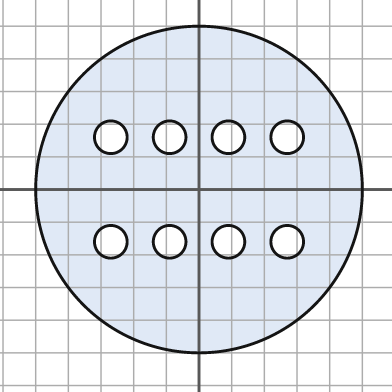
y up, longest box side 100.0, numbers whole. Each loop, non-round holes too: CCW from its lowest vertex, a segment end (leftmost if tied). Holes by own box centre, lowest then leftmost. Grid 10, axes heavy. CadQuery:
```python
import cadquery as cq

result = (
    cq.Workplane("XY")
    .moveTo(0.0, 0.0)
    .circle(50.0)
    .moveTo(-27.0, -16.0)
    .circle(5.0)
    .moveTo(-9.0, -16.0)
    .circle(5.0)
    .moveTo(9.0, -16.0)
    .circle(5.0)
    .moveTo(27.0, -16.0)
    .circle(5.0)
    .moveTo(-27.0, 16.0)
    .circle(5.0)
    .moveTo(-9.0, 16.0)
    .circle(5.0)
    .moveTo(9.0, 16.0)
    .circle(5.0)
    .moveTo(27.0, 16.0)
    .circle(5.0)
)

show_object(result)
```